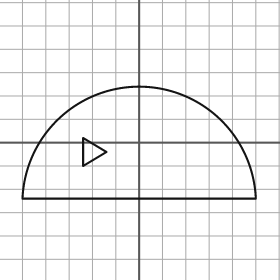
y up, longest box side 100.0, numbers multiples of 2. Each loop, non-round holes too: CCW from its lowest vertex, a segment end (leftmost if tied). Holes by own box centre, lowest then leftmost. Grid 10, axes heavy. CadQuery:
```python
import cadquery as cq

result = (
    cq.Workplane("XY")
    .moveTo(-50.0, -24.0)
    .lineTo(50.0, -24.0)
    .threePointArc((0.0, 24.0), (-50.0, -24.0))
    .close()
    .moveTo(-24.0, -10.0)
    .lineTo(-14.0, -4.0)
    .lineTo(-24.0, 2.0)
    .close()
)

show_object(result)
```